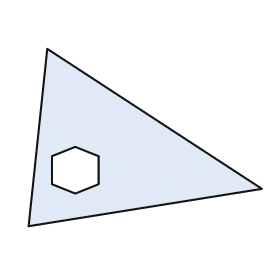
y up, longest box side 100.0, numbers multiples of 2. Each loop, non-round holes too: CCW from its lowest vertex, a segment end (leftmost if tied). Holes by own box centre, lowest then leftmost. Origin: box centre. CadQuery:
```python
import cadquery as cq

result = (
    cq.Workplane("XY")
    .moveTo(-50.0, -38.0)
    .lineTo(50.0, -22.0)
    .lineTo(-42.0, 38.0)
    .close()
    .moveTo(-30.0, -24.0)
    .lineTo(-20.0, -20.0)
    .lineTo(-20.0, -8.0)
    .lineTo(-30.0, -4.0)
    .lineTo(-40.0, -8.0)
    .lineTo(-40.0, -20.0)
    .close()
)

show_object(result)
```